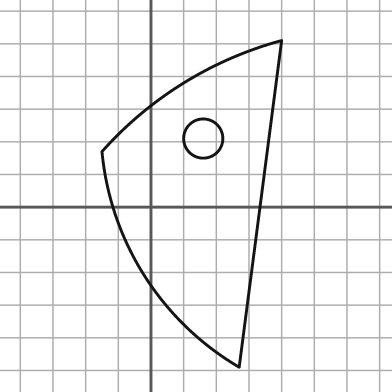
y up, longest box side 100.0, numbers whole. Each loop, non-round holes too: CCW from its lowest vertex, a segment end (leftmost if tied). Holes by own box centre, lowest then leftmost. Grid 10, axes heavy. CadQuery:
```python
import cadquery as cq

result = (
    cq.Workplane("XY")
    .moveTo(27.0, -49.0)
    .lineTo(40.0, 51.0)
    .threePointArc((10.0, 38.0), (-15.0, 17.0))
    .threePointArc((-2.0, -21.0), (27.0, -49.0))
    .close()
    .moveTo(16.0, 21.0)
    .circle(6.0)
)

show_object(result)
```